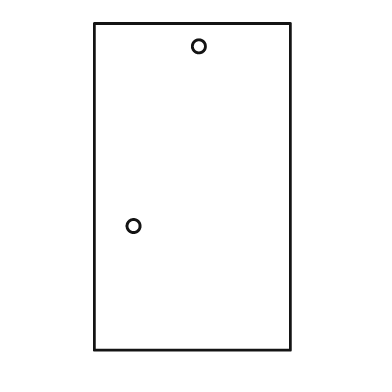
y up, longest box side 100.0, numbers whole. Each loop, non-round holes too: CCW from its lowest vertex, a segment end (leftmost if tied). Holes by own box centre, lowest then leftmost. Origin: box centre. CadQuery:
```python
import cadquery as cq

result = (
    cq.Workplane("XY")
    .moveTo(-30.0, -50.0)
    .lineTo(30.0, -50.0)
    .lineTo(30.0, 50.0)
    .lineTo(-30.0, 50.0)
    .close()
    .moveTo(-18.0, -12.0)
    .circle(2.0)
    .moveTo(2.0, 43.0)
    .circle(2.0)
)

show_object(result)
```